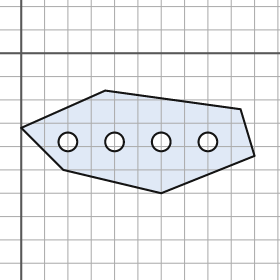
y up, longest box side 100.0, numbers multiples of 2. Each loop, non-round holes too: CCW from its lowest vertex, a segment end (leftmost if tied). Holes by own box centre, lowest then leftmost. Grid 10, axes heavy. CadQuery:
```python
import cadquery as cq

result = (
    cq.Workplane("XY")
    .moveTo(60.0, -60.0)
    .lineTo(100.0, -44.0)
    .lineTo(94.0, -24.0)
    .lineTo(36.0, -16.0)
    .lineTo(0.0, -32.0)
    .lineTo(18.0, -50.0)
    .close()
    .moveTo(20.0, -38.0)
    .circle(4.0)
    .moveTo(40.0, -38.0)
    .circle(4.0)
    .moveTo(60.0, -38.0)
    .circle(4.0)
    .moveTo(80.0, -38.0)
    .circle(4.0)
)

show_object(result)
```